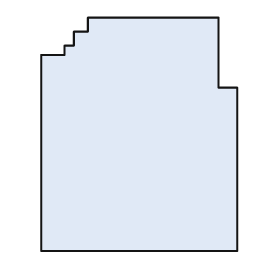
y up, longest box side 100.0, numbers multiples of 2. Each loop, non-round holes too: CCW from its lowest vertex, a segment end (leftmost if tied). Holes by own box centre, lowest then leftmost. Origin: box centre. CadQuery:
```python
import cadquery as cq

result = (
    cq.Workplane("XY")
    .moveTo(-42.0, -50.0)
    .lineTo(42.0, -50.0)
    .lineTo(42.0, 20.0)
    .lineTo(34.0, 20.0)
    .lineTo(34.0, 50.0)
    .lineTo(-22.0, 50.0)
    .lineTo(-22.0, 44.0)
    .lineTo(-28.0, 44.0)
    .lineTo(-28.0, 38.0)
    .lineTo(-32.0, 38.0)
    .lineTo(-32.0, 34.0)
    .lineTo(-42.0, 34.0)
    .close()
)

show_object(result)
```